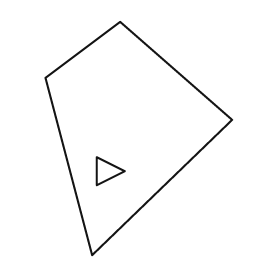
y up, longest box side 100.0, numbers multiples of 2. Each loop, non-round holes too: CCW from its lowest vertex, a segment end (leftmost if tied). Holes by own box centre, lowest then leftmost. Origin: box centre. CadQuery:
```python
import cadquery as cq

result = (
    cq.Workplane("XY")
    .moveTo(-20.0, -50.0)
    .lineTo(40.0, 8.0)
    .lineTo(-8.0, 50.0)
    .lineTo(-40.0, 26.0)
    .close()
    .moveTo(-18.0, -20.0)
    .lineTo(-6.0, -14.0)
    .lineTo(-18.0, -8.0)
    .close()
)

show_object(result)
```